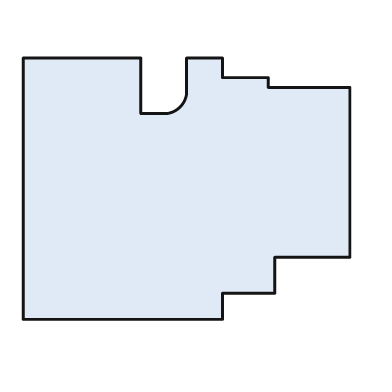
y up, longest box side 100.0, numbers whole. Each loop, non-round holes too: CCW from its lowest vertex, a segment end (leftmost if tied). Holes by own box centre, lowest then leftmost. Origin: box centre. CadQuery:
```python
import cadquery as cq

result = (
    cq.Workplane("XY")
    .moveTo(-50.0, -40.0)
    .lineTo(11.0, -40.0)
    .lineTo(11.0, -32.0)
    .lineTo(27.0, -32.0)
    .lineTo(27.0, -21.0)
    .lineTo(50.0, -21.0)
    .lineTo(50.0, 31.0)
    .lineTo(25.0, 31.0)
    .lineTo(25.0, 34.0)
    .lineTo(11.0, 34.0)
    .lineTo(11.0, 40.0)
    .lineTo(0.0, 40.0)
    .lineTo(0.0, 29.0)
    .threePointArc((-2.0, 25.0), (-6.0, 23.0))
    .lineTo(-14.0, 23.0)
    .lineTo(-14.0, 40.0)
    .lineTo(-50.0, 40.0)
    .close()
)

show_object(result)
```